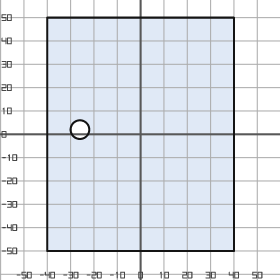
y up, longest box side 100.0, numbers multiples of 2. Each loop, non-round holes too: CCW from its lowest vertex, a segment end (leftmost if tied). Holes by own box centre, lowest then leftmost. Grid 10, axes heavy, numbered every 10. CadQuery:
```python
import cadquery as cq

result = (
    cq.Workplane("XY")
    .moveTo(-40.0, -50.0)
    .lineTo(40.0, -50.0)
    .lineTo(40.0, 50.0)
    .lineTo(-40.0, 50.0)
    .close()
    .moveTo(-26.0, 2.0)
    .circle(4.0)
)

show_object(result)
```